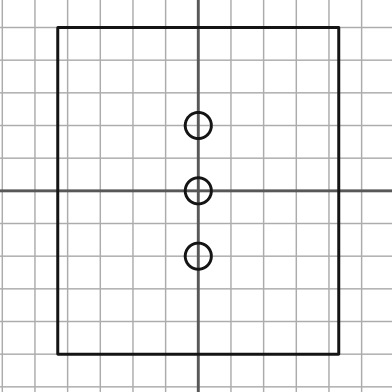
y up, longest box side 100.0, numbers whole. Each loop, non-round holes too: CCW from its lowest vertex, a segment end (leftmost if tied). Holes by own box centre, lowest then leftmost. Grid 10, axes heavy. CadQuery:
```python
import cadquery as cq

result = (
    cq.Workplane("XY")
    .moveTo(-43.0, -50.0)
    .lineTo(43.0, -50.0)
    .lineTo(43.0, 50.0)
    .lineTo(-43.0, 50.0)
    .close()
    .moveTo(0.0, -20.0)
    .circle(4.0)
    .moveTo(0.0, 0.0)
    .circle(4.0)
    .moveTo(0.0, 20.0)
    .circle(4.0)
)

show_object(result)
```